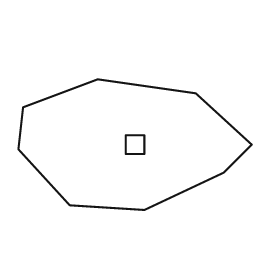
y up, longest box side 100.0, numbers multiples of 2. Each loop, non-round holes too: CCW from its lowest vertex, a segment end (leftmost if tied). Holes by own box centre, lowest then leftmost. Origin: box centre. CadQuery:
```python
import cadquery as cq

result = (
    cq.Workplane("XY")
    .moveTo(4.0, -28.0)
    .lineTo(38.0, -12.0)
    .lineTo(50.0, 0.0)
    .lineTo(26.0, 22.0)
    .lineTo(-16.0, 28.0)
    .lineTo(-48.0, 16.0)
    .lineTo(-50.0, -2.0)
    .lineTo(-28.0, -26.0)
    .close()
    .moveTo(-4.0, -4.0)
    .lineTo(4.0, -4.0)
    .lineTo(4.0, 4.0)
    .lineTo(-4.0, 4.0)
    .close()
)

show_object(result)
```